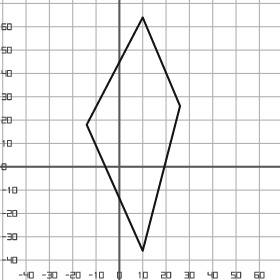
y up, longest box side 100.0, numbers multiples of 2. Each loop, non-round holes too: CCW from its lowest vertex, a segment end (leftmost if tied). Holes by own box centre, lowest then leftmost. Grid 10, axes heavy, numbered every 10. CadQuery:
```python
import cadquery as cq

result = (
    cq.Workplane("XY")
    .moveTo(10.0, -36.0)
    .lineTo(26.0, 26.0)
    .lineTo(10.0, 64.0)
    .lineTo(-14.0, 18.0)
    .close()
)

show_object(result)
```